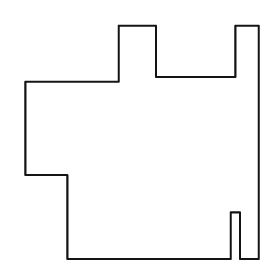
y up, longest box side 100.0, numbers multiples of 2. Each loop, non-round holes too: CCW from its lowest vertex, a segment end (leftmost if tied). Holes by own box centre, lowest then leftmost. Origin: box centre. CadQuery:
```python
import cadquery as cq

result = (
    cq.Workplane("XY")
    .moveTo(-32.0, -50.0)
    .lineTo(38.0, -50.0)
    .lineTo(38.0, -30.0)
    .lineTo(42.0, -30.0)
    .lineTo(42.0, -50.0)
    .lineTo(50.0, -50.0)
    .lineTo(50.0, 50.0)
    .lineTo(40.0, 50.0)
    .lineTo(40.0, 28.0)
    .lineTo(6.0, 28.0)
    .lineTo(6.0, 50.0)
    .lineTo(-10.0, 50.0)
    .lineTo(-10.0, 26.0)
    .lineTo(-50.0, 26.0)
    .lineTo(-50.0, -14.0)
    .lineTo(-32.0, -14.0)
    .close()
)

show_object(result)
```